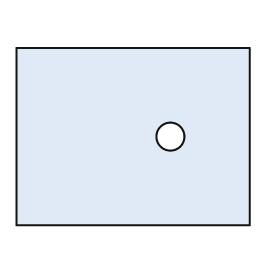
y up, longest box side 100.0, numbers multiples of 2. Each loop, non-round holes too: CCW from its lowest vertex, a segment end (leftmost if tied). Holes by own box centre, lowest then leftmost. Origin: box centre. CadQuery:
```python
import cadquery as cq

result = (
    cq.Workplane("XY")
    .moveTo(-50.0, -38.0)
    .lineTo(50.0, -38.0)
    .lineTo(50.0, 38.0)
    .lineTo(-50.0, 38.0)
    .close()
    .moveTo(16.0, 0.0)
    .circle(6.0)
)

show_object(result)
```